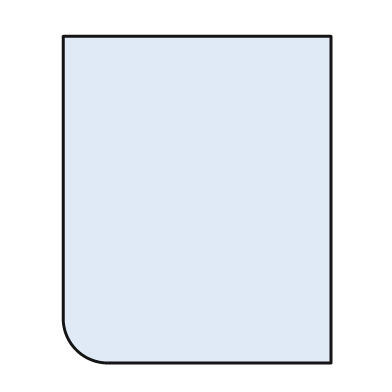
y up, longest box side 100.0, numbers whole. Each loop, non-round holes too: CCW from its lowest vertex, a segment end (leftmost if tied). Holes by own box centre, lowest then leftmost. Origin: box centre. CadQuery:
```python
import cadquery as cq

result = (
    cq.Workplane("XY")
    .moveTo(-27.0, -50.0)
    .lineTo(41.0, -50.0)
    .lineTo(41.0, 50.0)
    .lineTo(-41.0, 50.0)
    .lineTo(-41.0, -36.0)
    .threePointArc((-37.0, -46.0), (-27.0, -50.0))
    .close()
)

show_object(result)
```